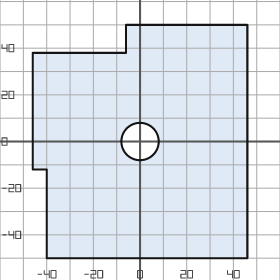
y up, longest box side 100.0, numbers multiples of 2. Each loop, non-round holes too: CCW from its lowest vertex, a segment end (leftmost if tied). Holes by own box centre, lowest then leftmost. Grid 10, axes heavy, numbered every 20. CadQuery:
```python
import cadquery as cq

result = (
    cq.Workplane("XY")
    .moveTo(-40.0, -50.0)
    .lineTo(46.0, -50.0)
    .lineTo(46.0, 50.0)
    .lineTo(-6.0, 50.0)
    .lineTo(-6.0, 38.0)
    .lineTo(-46.0, 38.0)
    .lineTo(-46.0, -12.0)
    .lineTo(-40.0, -12.0)
    .close()
    .moveTo(0.0, 0.0)
    .circle(8.0)
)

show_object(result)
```